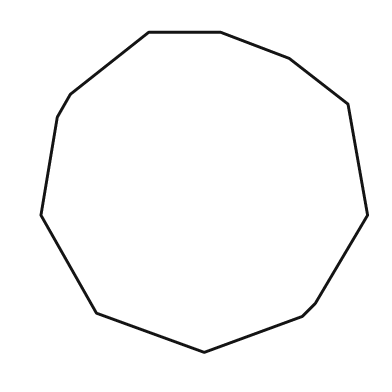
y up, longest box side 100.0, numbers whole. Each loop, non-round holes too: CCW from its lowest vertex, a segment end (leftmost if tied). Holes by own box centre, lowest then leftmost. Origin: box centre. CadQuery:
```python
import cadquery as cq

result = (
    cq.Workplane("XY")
    .moveTo(0.0, -49.0)
    .lineTo(30.0, -38.0)
    .lineTo(34.0, -34.0)
    .lineTo(50.0, -7.0)
    .lineTo(44.0, 27.0)
    .lineTo(26.0, 41.0)
    .lineTo(5.0, 49.0)
    .lineTo(-17.0, 49.0)
    .lineTo(-41.0, 30.0)
    .lineTo(-45.0, 23.0)
    .lineTo(-50.0, -7.0)
    .lineTo(-33.0, -37.0)
    .close()
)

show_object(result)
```